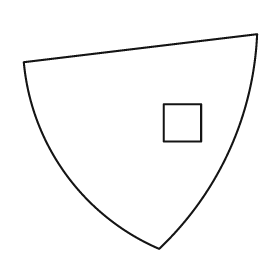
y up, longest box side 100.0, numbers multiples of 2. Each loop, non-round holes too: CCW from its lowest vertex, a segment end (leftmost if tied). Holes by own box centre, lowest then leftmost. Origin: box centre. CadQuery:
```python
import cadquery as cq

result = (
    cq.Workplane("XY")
    .moveTo(8.0, -46.0)
    .threePointArc((38.0, -4.0), (50.0, 46.0))
    .lineTo(-50.0, 34.0)
    .threePointArc((-32.0, -14.0), (8.0, -46.0))
    .close()
    .moveTo(10.0, 0.0)
    .lineTo(26.0, 0.0)
    .lineTo(26.0, 16.0)
    .lineTo(10.0, 16.0)
    .close()
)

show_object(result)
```